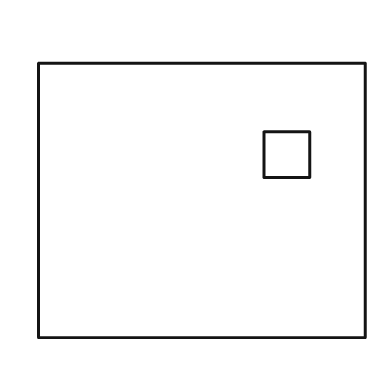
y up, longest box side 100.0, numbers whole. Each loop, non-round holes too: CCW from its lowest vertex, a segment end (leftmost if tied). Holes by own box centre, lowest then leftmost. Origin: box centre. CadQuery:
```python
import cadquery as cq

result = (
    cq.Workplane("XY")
    .moveTo(-50.0, -42.0)
    .lineTo(50.0, -42.0)
    .lineTo(50.0, 42.0)
    .lineTo(-50.0, 42.0)
    .close()
    .moveTo(19.0, 7.0)
    .lineTo(33.0, 7.0)
    .lineTo(33.0, 21.0)
    .lineTo(19.0, 21.0)
    .close()
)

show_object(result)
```